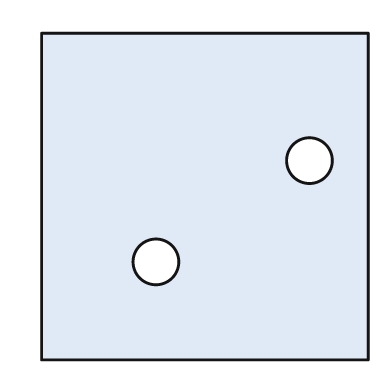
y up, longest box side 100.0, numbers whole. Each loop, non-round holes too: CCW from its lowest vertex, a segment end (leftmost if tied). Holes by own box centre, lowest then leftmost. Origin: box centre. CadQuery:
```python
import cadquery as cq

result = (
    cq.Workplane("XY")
    .moveTo(-50.0, -50.0)
    .lineTo(50.0, -50.0)
    .lineTo(50.0, 50.0)
    .lineTo(-50.0, 50.0)
    .close()
    .moveTo(-15.0, -20.0)
    .circle(7.0)
    .moveTo(32.0, 11.0)
    .circle(7.0)
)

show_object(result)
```